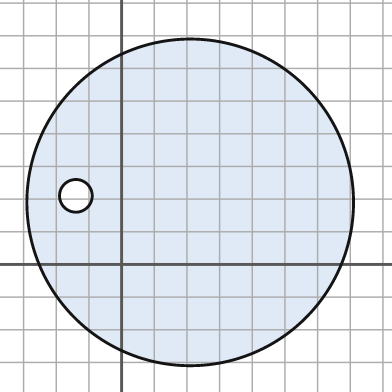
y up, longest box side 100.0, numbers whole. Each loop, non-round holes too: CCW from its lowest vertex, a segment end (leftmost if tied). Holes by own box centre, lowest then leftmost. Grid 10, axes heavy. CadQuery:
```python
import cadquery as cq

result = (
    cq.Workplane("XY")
    .moveTo(21.0, 19.0)
    .circle(50.0)
    .moveTo(-14.0, 21.0)
    .circle(5.0)
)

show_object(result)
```